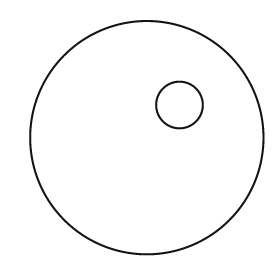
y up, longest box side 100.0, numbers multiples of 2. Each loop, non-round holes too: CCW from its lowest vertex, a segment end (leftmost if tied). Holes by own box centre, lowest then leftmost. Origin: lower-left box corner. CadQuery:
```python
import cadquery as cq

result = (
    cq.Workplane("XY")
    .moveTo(50.0, 50.0)
    .circle(50.0)
    .moveTo(64.0, 64.0)
    .circle(10.0)
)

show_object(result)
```